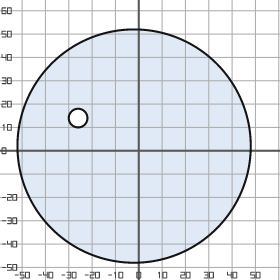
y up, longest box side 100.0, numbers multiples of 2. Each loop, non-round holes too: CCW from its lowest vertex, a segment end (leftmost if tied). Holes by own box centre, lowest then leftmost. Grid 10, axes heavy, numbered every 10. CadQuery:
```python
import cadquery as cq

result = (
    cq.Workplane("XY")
    .moveTo(-2.0, 2.0)
    .circle(50.0)
    .moveTo(-26.0, 14.0)
    .circle(4.0)
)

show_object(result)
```